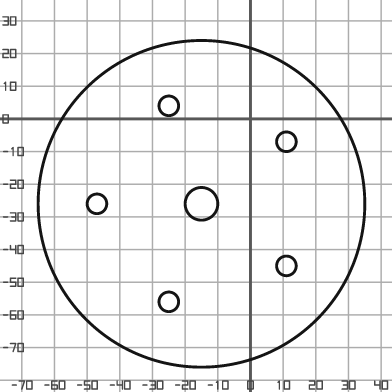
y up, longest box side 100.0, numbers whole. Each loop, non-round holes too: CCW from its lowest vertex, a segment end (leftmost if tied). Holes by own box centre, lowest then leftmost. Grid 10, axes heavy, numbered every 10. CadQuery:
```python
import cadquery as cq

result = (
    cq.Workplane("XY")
    .moveTo(-15.0, -26.0)
    .circle(50.0)
    .moveTo(-25.0, -56.0)
    .circle(3.0)
    .moveTo(11.0, -45.0)
    .circle(3.0)
    .moveTo(-47.0, -26.0)
    .circle(3.0)
    .moveTo(-15.0, -26.0)
    .circle(5.0)
    .moveTo(11.0, -7.0)
    .circle(3.0)
    .moveTo(-25.0, 4.0)
    .circle(3.0)
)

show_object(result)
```